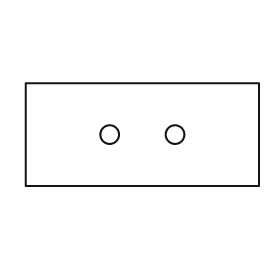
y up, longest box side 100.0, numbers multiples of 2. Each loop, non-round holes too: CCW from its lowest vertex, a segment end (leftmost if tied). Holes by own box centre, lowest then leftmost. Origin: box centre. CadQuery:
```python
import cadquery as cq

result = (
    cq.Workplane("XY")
    .moveTo(-50.0, -22.0)
    .lineTo(50.0, -22.0)
    .lineTo(50.0, 22.0)
    .lineTo(-50.0, 22.0)
    .close()
    .moveTo(-14.0, 0.0)
    .circle(4.0)
    .moveTo(14.0, 0.0)
    .circle(4.0)
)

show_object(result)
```